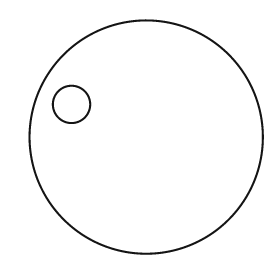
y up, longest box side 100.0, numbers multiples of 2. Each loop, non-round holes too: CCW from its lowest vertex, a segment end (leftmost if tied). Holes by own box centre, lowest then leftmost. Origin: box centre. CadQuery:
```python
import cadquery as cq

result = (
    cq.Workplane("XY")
    .moveTo(0.0, 0.0)
    .circle(50.0)
    .moveTo(-32.0, 14.0)
    .circle(8.0)
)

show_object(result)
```